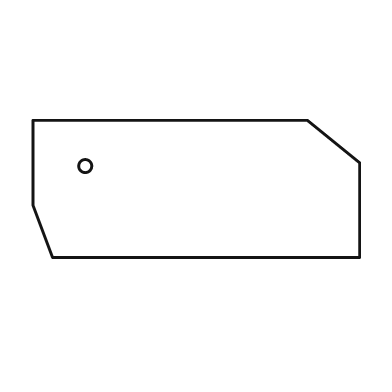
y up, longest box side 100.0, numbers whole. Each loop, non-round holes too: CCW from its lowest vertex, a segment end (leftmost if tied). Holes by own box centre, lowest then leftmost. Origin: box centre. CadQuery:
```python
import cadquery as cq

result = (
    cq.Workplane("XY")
    .moveTo(-44.0, -21.0)
    .lineTo(50.0, -21.0)
    .lineTo(50.0, 8.0)
    .lineTo(34.0, 21.0)
    .lineTo(-50.0, 21.0)
    .lineTo(-50.0, -5.0)
    .close()
    .moveTo(-34.0, 7.0)
    .circle(2.0)
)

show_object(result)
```